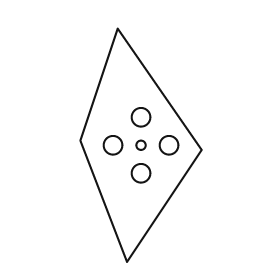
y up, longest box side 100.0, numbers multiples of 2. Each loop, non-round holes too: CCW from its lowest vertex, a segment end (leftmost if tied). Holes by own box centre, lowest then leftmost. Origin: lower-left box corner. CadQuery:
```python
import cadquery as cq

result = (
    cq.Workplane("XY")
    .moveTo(20.0, 0.0)
    .lineTo(52.0, 48.0)
    .lineTo(16.0, 100.0)
    .lineTo(0.0, 52.0)
    .close()
    .moveTo(26.0, 38.0)
    .circle(4.0)
    .moveTo(14.0, 50.0)
    .circle(4.0)
    .moveTo(26.0, 50.0)
    .circle(2.0)
    .moveTo(38.0, 50.0)
    .circle(4.0)
    .moveTo(26.0, 62.0)
    .circle(4.0)
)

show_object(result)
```